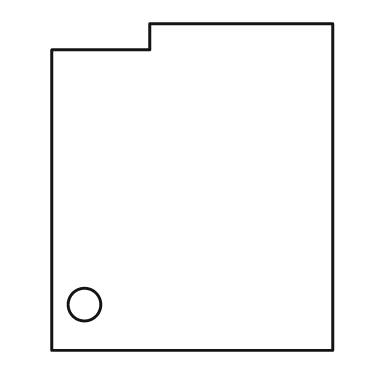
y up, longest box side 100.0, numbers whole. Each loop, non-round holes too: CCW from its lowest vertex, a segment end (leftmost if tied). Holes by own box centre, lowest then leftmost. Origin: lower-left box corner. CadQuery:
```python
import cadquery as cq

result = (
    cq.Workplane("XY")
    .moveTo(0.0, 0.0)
    .lineTo(86.0, 0.0)
    .lineTo(86.0, 100.0)
    .lineTo(30.0, 100.0)
    .lineTo(30.0, 92.0)
    .lineTo(0.0, 92.0)
    .close()
    .moveTo(10.0, 14.0)
    .circle(5.0)
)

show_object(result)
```